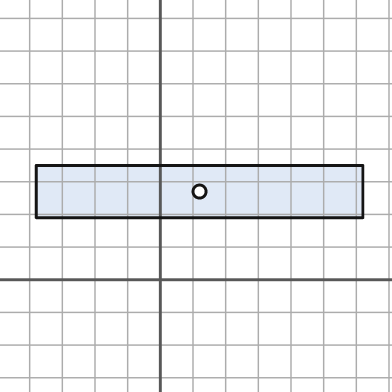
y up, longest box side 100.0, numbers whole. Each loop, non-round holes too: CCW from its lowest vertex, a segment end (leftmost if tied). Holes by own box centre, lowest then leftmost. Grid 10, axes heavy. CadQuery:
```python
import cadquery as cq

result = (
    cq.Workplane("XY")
    .moveTo(-38.0, 19.0)
    .lineTo(62.0, 19.0)
    .lineTo(62.0, 35.0)
    .lineTo(-38.0, 35.0)
    .close()
    .moveTo(12.0, 27.0)
    .circle(2.0)
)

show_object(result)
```